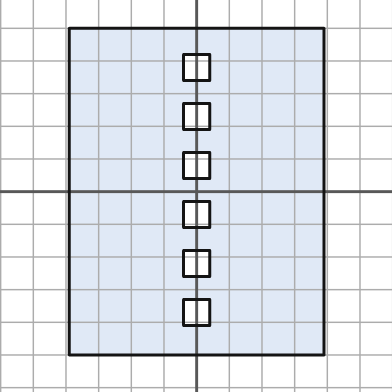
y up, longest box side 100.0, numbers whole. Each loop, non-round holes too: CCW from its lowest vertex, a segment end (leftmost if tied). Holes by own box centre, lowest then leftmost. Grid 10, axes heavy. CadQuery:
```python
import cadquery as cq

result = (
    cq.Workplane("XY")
    .moveTo(-39.0, -50.0)
    .lineTo(39.0, -50.0)
    .lineTo(39.0, 50.0)
    .lineTo(-39.0, 50.0)
    .close()
    .moveTo(-4.0, -41.0)
    .lineTo(4.0, -41.0)
    .lineTo(4.0, -33.0)
    .lineTo(-4.0, -33.0)
    .close()
    .moveTo(-4.0, -26.0)
    .lineTo(4.0, -26.0)
    .lineTo(4.0, -18.0)
    .lineTo(-4.0, -18.0)
    .close()
    .moveTo(-4.0, -11.0)
    .lineTo(4.0, -11.0)
    .lineTo(4.0, -3.0)
    .lineTo(-4.0, -3.0)
    .close()
    .moveTo(-4.0, 4.0)
    .lineTo(4.0, 4.0)
    .lineTo(4.0, 12.0)
    .lineTo(-4.0, 12.0)
    .close()
    .moveTo(-4.0, 19.0)
    .lineTo(4.0, 19.0)
    .lineTo(4.0, 27.0)
    .lineTo(-4.0, 27.0)
    .close()
    .moveTo(-4.0, 34.0)
    .lineTo(4.0, 34.0)
    .lineTo(4.0, 42.0)
    .lineTo(-4.0, 42.0)
    .close()
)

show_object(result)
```